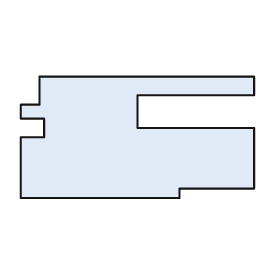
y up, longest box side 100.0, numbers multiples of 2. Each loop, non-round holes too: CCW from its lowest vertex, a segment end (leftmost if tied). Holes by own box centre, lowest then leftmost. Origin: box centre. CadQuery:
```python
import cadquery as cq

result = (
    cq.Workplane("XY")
    .moveTo(-50.0, -26.0)
    .lineTo(18.0, -26.0)
    .lineTo(18.0, -22.0)
    .lineTo(50.0, -22.0)
    .lineTo(50.0, 4.0)
    .lineTo(0.0, 4.0)
    .lineTo(0.0, 18.0)
    .lineTo(50.0, 18.0)
    .lineTo(50.0, 26.0)
    .lineTo(-42.0, 26.0)
    .lineTo(-42.0, 14.0)
    .lineTo(-50.0, 14.0)
    .lineTo(-50.0, 8.0)
    .lineTo(-40.0, 8.0)
    .lineTo(-40.0, 0.0)
    .lineTo(-50.0, 0.0)
    .close()
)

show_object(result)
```